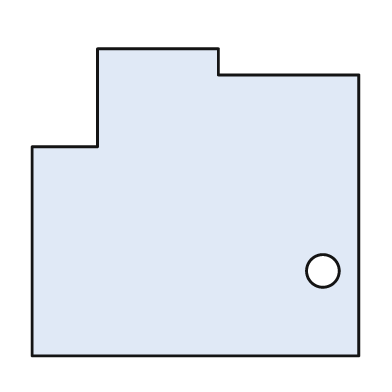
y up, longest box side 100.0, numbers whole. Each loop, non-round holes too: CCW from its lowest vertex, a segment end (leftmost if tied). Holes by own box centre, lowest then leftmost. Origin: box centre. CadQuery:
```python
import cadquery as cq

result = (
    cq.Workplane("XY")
    .moveTo(-50.0, -47.0)
    .lineTo(50.0, -47.0)
    .lineTo(50.0, 39.0)
    .lineTo(7.0, 39.0)
    .lineTo(7.0, 47.0)
    .lineTo(-30.0, 47.0)
    .lineTo(-30.0, 17.0)
    .lineTo(-50.0, 17.0)
    .close()
    .moveTo(39.0, -21.0)
    .circle(5.0)
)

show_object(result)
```